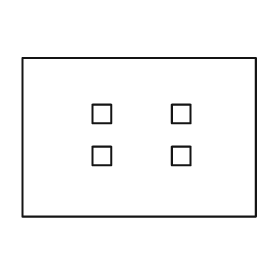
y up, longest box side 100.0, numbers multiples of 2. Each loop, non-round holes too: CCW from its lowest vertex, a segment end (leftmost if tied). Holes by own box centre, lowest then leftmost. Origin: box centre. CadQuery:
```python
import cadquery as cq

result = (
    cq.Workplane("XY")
    .moveTo(-50.0, -34.0)
    .lineTo(50.0, -34.0)
    .lineTo(50.0, 34.0)
    .lineTo(-50.0, 34.0)
    .close()
    .moveTo(-20.0, -12.0)
    .lineTo(-12.0, -12.0)
    .lineTo(-12.0, -4.0)
    .lineTo(-20.0, -4.0)
    .close()
    .moveTo(14.0, -12.0)
    .lineTo(22.0, -12.0)
    .lineTo(22.0, -4.0)
    .lineTo(14.0, -4.0)
    .close()
    .moveTo(-20.0, 6.0)
    .lineTo(-12.0, 6.0)
    .lineTo(-12.0, 14.0)
    .lineTo(-20.0, 14.0)
    .close()
    .moveTo(14.0, 6.0)
    .lineTo(22.0, 6.0)
    .lineTo(22.0, 14.0)
    .lineTo(14.0, 14.0)
    .close()
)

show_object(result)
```